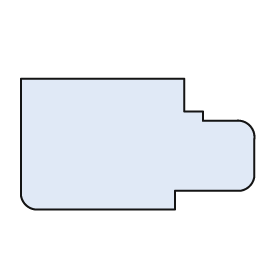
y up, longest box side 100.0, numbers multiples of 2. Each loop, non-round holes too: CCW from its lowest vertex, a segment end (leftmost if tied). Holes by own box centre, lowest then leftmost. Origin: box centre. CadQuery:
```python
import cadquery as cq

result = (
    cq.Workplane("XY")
    .moveTo(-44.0, -28.0)
    .lineTo(16.0, -28.0)
    .lineTo(16.0, -20.0)
    .lineTo(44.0, -20.0)
    .threePointArc((48.0, -18.0), (50.0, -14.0))
    .lineTo(50.0, 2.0)
    .threePointArc((48.0, 8.0), (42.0, 10.0))
    .lineTo(28.0, 10.0)
    .lineTo(28.0, 14.0)
    .lineTo(20.0, 14.0)
    .lineTo(20.0, 28.0)
    .lineTo(-50.0, 28.0)
    .lineTo(-50.0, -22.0)
    .threePointArc((-48.0, -26.0), (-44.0, -28.0))
    .close()
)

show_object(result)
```